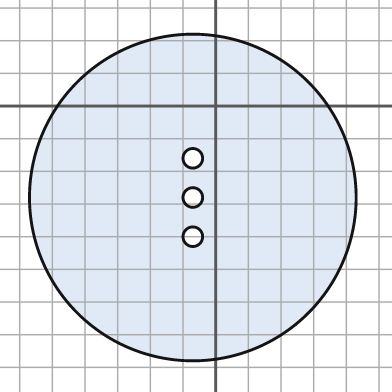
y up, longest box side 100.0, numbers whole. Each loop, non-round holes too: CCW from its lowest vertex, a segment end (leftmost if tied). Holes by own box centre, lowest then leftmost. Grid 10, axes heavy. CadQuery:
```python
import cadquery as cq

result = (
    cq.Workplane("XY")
    .moveTo(-7.0, -28.0)
    .circle(50.0)
    .moveTo(-7.0, -40.0)
    .circle(3.0)
    .moveTo(-7.0, -28.0)
    .circle(3.0)
    .moveTo(-7.0, -16.0)
    .circle(3.0)
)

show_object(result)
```